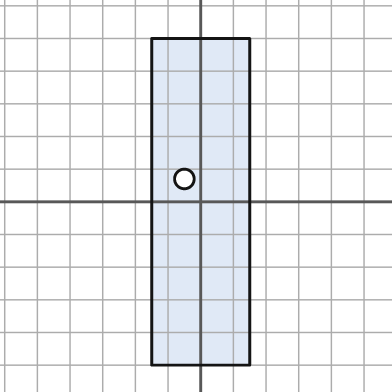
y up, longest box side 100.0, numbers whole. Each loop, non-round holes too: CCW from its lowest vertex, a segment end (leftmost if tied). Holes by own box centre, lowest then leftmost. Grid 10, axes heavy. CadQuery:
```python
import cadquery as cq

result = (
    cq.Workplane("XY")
    .moveTo(-15.0, -50.0)
    .lineTo(15.0, -50.0)
    .lineTo(15.0, 50.0)
    .lineTo(-15.0, 50.0)
    .close()
    .moveTo(-5.0, 7.0)
    .circle(3.0)
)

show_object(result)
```